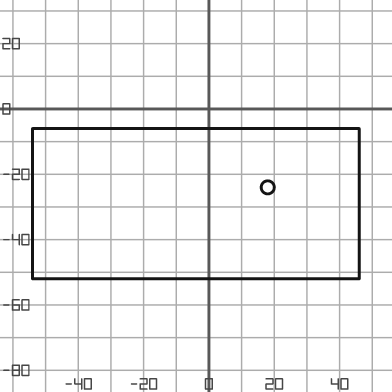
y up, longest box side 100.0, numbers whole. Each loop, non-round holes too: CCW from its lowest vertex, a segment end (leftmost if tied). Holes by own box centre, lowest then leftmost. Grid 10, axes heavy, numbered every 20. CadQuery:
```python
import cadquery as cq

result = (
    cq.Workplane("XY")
    .moveTo(-54.0, -52.0)
    .lineTo(46.0, -52.0)
    .lineTo(46.0, -6.0)
    .lineTo(-54.0, -6.0)
    .close()
    .moveTo(18.0, -24.0)
    .circle(2.0)
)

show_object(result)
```